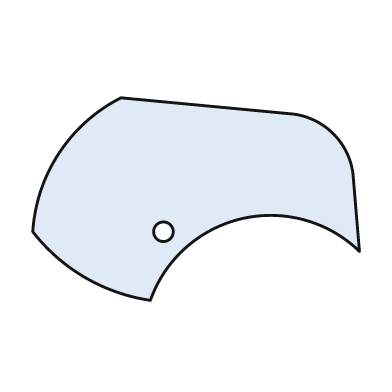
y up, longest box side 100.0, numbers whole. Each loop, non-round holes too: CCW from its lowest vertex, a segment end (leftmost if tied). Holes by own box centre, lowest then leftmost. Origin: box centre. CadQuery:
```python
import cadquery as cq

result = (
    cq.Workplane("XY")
    .moveTo(-14.0, -31.0)
    .threePointArc((14.0, -6.0), (50.0, -16.0))
    .lineTo(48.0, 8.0)
    .threePointArc((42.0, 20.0), (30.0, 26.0))
    .lineTo(-23.0, 31.0)
    .threePointArc((-42.0, 14.0), (-50.0, -10.0))
    .threePointArc((-34.0, -24.0), (-14.0, -31.0))
    .close()
    .moveTo(-10.0, -10.0)
    .circle(3.0)
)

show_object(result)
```